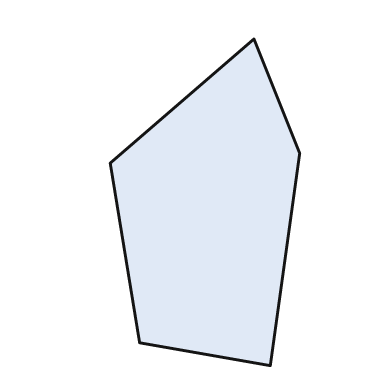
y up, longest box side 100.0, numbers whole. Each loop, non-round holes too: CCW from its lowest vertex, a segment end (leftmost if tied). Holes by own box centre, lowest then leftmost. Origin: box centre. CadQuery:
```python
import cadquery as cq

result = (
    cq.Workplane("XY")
    .moveTo(20.0, -50.0)
    .lineTo(29.0, 15.0)
    .lineTo(15.0, 50.0)
    .lineTo(-29.0, 12.0)
    .lineTo(-20.0, -43.0)
    .close()
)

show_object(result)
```